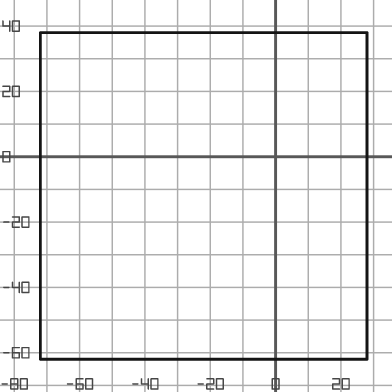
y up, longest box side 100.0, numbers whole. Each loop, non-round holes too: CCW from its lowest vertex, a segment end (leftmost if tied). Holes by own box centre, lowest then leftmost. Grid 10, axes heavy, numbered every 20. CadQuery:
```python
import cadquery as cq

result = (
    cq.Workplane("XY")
    .moveTo(-72.0, -62.0)
    .lineTo(28.0, -62.0)
    .lineTo(28.0, 38.0)
    .lineTo(-72.0, 38.0)
    .close()
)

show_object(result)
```